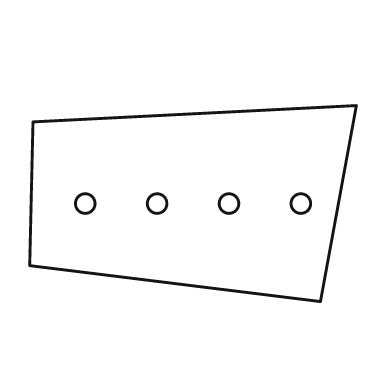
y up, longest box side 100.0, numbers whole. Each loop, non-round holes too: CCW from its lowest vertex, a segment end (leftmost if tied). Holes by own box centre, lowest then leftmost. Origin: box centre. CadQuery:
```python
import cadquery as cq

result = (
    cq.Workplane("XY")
    .moveTo(39.0, -30.0)
    .lineTo(50.0, 30.0)
    .lineTo(-49.0, 25.0)
    .lineTo(-50.0, -19.0)
    .close()
    .moveTo(-33.0, 0.0)
    .circle(3.0)
    .moveTo(-11.0, 0.0)
    .circle(3.0)
    .moveTo(11.0, 0.0)
    .circle(3.0)
    .moveTo(33.0, 0.0)
    .circle(3.0)
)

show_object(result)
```